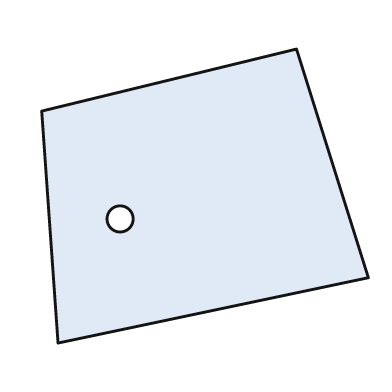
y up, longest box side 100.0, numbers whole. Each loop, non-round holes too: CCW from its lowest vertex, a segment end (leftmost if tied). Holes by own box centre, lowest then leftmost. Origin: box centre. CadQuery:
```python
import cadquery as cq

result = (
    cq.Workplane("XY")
    .moveTo(-45.0, -45.0)
    .lineTo(50.0, -25.0)
    .lineTo(28.0, 45.0)
    .lineTo(-50.0, 26.0)
    .close()
    .moveTo(-26.0, -7.0)
    .circle(4.0)
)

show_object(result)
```